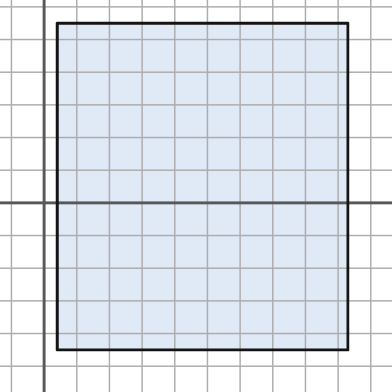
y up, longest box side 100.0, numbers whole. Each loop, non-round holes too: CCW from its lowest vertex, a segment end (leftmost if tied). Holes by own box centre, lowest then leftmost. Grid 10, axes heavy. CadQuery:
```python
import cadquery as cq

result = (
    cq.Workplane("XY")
    .moveTo(4.0, -45.0)
    .lineTo(93.0, -45.0)
    .lineTo(93.0, 55.0)
    .lineTo(4.0, 55.0)
    .close()
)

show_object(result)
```